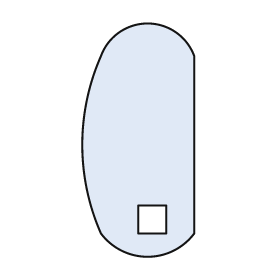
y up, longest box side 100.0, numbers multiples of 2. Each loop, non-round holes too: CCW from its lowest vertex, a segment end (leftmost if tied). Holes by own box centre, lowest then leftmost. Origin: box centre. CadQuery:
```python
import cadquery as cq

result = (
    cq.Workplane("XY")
    .moveTo(-16.0, -40.0)
    .threePointArc((4.0, -50.0), (24.0, -40.0))
    .lineTo(24.0, 36.0)
    .threePointArc((4.0, 50.0), (-16.0, 36.0))
    .threePointArc((-24.0, -2.0), (-16.0, -40.0))
    .close()
    .moveTo(0.0, -40.0)
    .lineTo(12.0, -40.0)
    .lineTo(12.0, -28.0)
    .lineTo(0.0, -28.0)
    .close()
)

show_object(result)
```